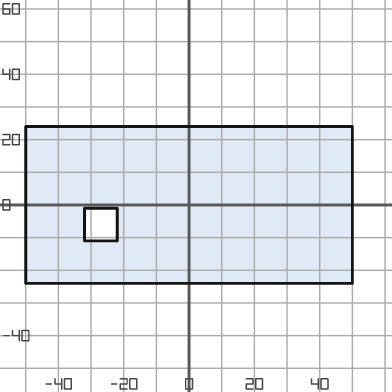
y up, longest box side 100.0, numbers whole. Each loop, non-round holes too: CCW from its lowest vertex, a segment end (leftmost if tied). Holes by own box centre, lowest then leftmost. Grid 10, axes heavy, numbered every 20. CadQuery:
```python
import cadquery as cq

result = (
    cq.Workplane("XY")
    .moveTo(-50.0, -24.0)
    .lineTo(50.0, -24.0)
    .lineTo(50.0, 24.0)
    .lineTo(-50.0, 24.0)
    .close()
    .moveTo(-32.0, -11.0)
    .lineTo(-22.0, -11.0)
    .lineTo(-22.0, -1.0)
    .lineTo(-32.0, -1.0)
    .close()
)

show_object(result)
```